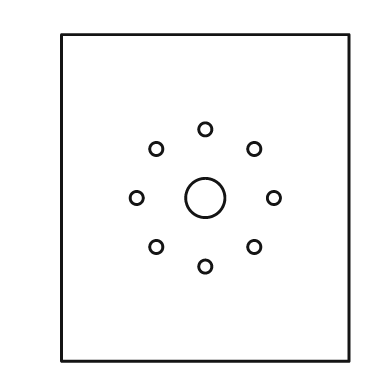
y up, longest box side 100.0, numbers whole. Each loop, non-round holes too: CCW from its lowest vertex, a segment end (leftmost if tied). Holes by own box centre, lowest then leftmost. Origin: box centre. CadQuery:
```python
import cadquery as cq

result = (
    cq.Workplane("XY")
    .moveTo(-44.0, -50.0)
    .lineTo(44.0, -50.0)
    .lineTo(44.0, 50.0)
    .lineTo(-44.0, 50.0)
    .close()
    .moveTo(0.0, -21.0)
    .circle(2.0)
    .moveTo(-15.0, -15.0)
    .circle(2.0)
    .moveTo(15.0, -15.0)
    .circle(2.0)
    .moveTo(-21.0, 0.0)
    .circle(2.0)
    .moveTo(0.0, 0.0)
    .circle(6.0)
    .moveTo(21.0, 0.0)
    .circle(2.0)
    .moveTo(-15.0, 15.0)
    .circle(2.0)
    .moveTo(15.0, 15.0)
    .circle(2.0)
    .moveTo(0.0, 21.0)
    .circle(2.0)
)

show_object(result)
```